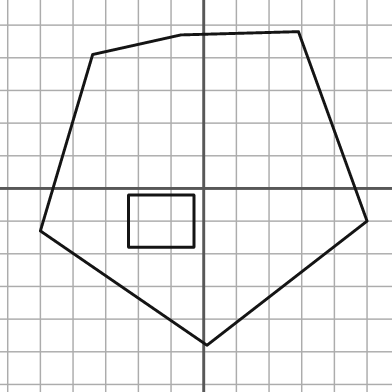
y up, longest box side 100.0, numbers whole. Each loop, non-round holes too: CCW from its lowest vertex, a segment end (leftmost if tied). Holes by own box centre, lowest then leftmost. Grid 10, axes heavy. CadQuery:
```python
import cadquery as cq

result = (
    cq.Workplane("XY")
    .moveTo(1.0, -48.0)
    .lineTo(50.0, -10.0)
    .lineTo(29.0, 48.0)
    .lineTo(-7.0, 47.0)
    .lineTo(-34.0, 41.0)
    .lineTo(-50.0, -13.0)
    .close()
    .moveTo(-23.0, -18.0)
    .lineTo(-3.0, -18.0)
    .lineTo(-3.0, -2.0)
    .lineTo(-23.0, -2.0)
    .close()
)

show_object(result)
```